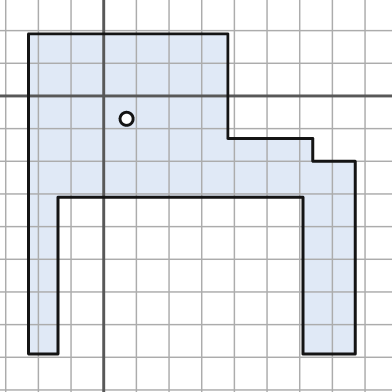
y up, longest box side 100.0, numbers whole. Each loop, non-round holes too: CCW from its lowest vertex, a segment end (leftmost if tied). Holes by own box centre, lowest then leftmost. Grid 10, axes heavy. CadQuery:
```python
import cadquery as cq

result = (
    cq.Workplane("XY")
    .moveTo(-23.0, -79.0)
    .lineTo(-14.0, -79.0)
    .lineTo(-14.0, -31.0)
    .lineTo(61.0, -31.0)
    .lineTo(61.0, -79.0)
    .lineTo(77.0, -79.0)
    .lineTo(77.0, -20.0)
    .lineTo(64.0, -20.0)
    .lineTo(64.0, -13.0)
    .lineTo(38.0, -13.0)
    .lineTo(38.0, 19.0)
    .lineTo(-23.0, 19.0)
    .close()
    .moveTo(7.0, -7.0)
    .circle(2.0)
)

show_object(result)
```